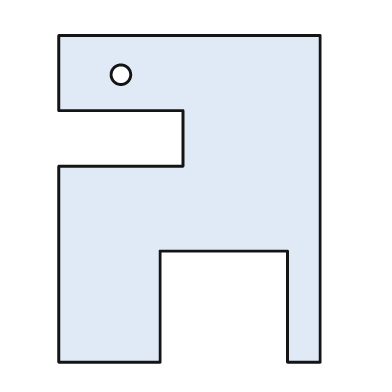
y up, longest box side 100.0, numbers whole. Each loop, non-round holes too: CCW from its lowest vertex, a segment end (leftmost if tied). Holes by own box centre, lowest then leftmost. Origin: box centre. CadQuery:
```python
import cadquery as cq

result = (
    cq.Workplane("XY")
    .moveTo(-40.0, -50.0)
    .lineTo(-9.0, -50.0)
    .lineTo(-9.0, -16.0)
    .lineTo(30.0, -16.0)
    .lineTo(30.0, -50.0)
    .lineTo(40.0, -50.0)
    .lineTo(40.0, 50.0)
    .lineTo(-40.0, 50.0)
    .lineTo(-40.0, 27.0)
    .lineTo(-2.0, 27.0)
    .lineTo(-2.0, 10.0)
    .lineTo(-40.0, 10.0)
    .close()
    .moveTo(-21.0, 38.0)
    .circle(3.0)
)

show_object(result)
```